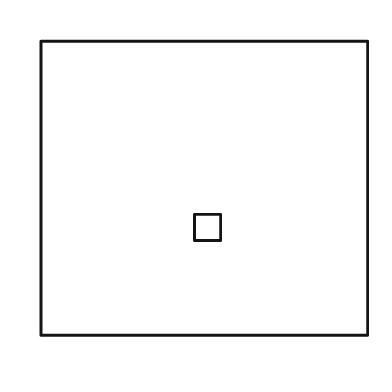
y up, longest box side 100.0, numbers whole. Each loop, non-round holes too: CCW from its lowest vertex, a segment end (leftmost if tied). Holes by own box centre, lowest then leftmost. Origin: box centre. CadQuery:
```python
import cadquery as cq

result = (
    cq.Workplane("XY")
    .moveTo(-50.0, -45.0)
    .lineTo(50.0, -45.0)
    .lineTo(50.0, 45.0)
    .lineTo(-50.0, 45.0)
    .close()
    .moveTo(-3.0, -16.0)
    .lineTo(5.0, -16.0)
    .lineTo(5.0, -8.0)
    .lineTo(-3.0, -8.0)
    .close()
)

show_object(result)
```